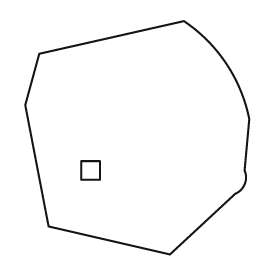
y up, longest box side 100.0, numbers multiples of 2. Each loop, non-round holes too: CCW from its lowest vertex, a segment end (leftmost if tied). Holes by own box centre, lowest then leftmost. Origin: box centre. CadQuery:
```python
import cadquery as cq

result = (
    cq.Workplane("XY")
    .moveTo(14.0, -50.0)
    .lineTo(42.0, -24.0)
    .threePointArc((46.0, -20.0), (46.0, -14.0))
    .lineTo(48.0, 8.0)
    .threePointArc((38.0, 32.0), (20.0, 50.0))
    .lineTo(-42.0, 36.0)
    .lineTo(-48.0, 14.0)
    .lineTo(-38.0, -38.0)
    .close()
    .moveTo(-24.0, -18.0)
    .lineTo(-16.0, -18.0)
    .lineTo(-16.0, -10.0)
    .lineTo(-24.0, -10.0)
    .close()
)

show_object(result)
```